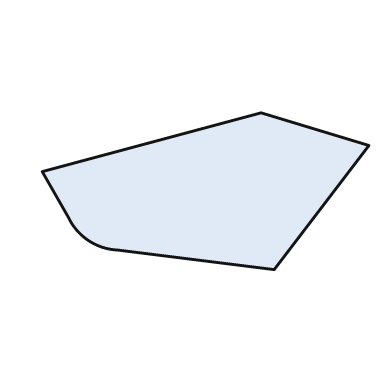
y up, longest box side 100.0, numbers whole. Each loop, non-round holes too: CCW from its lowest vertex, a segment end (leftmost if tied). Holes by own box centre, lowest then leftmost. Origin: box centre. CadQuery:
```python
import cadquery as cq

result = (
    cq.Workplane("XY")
    .moveTo(21.0, -24.0)
    .lineTo(50.0, 14.0)
    .lineTo(17.0, 24.0)
    .lineTo(-50.0, 6.0)
    .lineTo(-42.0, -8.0)
    .threePointArc((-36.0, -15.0), (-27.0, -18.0))
    .close()
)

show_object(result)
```